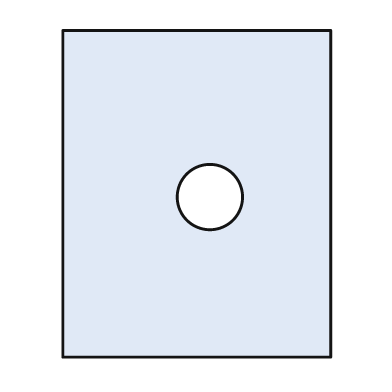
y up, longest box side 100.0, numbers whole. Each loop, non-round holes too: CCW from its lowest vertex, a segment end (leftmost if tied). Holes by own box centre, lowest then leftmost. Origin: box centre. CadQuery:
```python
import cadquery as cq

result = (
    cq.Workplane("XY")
    .moveTo(-41.0, -50.0)
    .lineTo(41.0, -50.0)
    .lineTo(41.0, 50.0)
    .lineTo(-41.0, 50.0)
    .close()
    .moveTo(4.0, -1.0)
    .circle(10.0)
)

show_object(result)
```